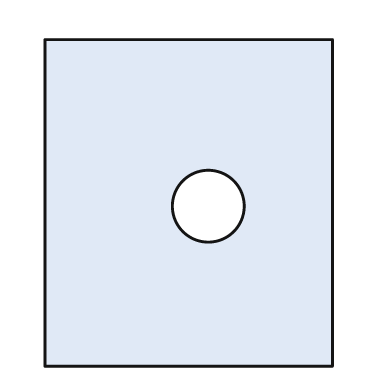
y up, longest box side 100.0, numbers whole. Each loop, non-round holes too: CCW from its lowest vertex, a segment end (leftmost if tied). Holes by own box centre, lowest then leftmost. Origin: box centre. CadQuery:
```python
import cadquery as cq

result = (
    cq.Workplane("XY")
    .moveTo(-44.0, -50.0)
    .lineTo(44.0, -50.0)
    .lineTo(44.0, 50.0)
    .lineTo(-44.0, 50.0)
    .close()
    .moveTo(6.0, -1.0)
    .circle(11.0)
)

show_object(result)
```